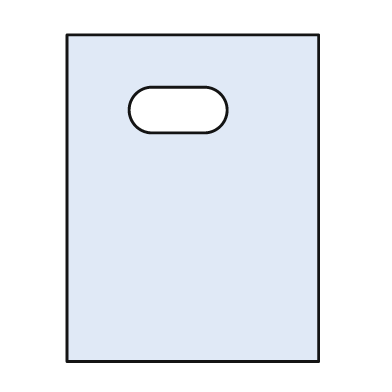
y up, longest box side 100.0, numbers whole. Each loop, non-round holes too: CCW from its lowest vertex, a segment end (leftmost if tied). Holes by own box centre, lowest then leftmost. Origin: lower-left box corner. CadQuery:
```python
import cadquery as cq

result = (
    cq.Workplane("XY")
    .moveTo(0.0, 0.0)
    .lineTo(77.0, 0.0)
    .lineTo(77.0, 100.0)
    .lineTo(0.0, 100.0)
    .close()
    .moveTo(26.0, 70.0)
    .lineTo(42.0, 70.0)
    .threePointArc((49.0, 77.0), (42.0, 84.0))
    .lineTo(26.0, 84.0)
    .threePointArc((19.0, 77.0), (26.0, 70.0))
    .close()
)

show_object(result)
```